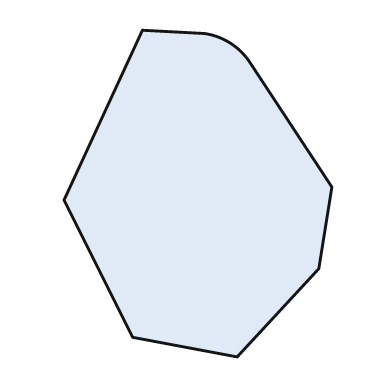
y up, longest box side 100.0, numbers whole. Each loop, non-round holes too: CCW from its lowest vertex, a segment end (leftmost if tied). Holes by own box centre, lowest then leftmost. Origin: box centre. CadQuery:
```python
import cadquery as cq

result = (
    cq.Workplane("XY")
    .moveTo(12.0, -50.0)
    .lineTo(37.0, -23.0)
    .lineTo(41.0, 2.0)
    .lineTo(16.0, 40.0)
    .threePointArc((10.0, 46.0), (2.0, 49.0))
    .lineTo(-17.0, 50.0)
    .lineTo(-41.0, -2.0)
    .lineTo(-20.0, -44.0)
    .close()
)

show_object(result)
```